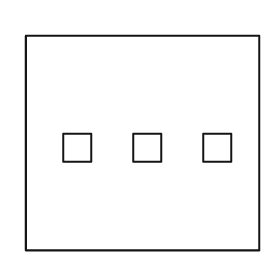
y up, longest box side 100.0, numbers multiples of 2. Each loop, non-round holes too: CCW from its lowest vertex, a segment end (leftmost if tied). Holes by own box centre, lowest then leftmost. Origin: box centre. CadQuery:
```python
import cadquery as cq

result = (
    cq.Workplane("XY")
    .moveTo(-50.0, -46.0)
    .lineTo(50.0, -46.0)
    .lineTo(50.0, 46.0)
    .lineTo(-50.0, 46.0)
    .close()
    .moveTo(-34.0, -8.0)
    .lineTo(-22.0, -8.0)
    .lineTo(-22.0, 4.0)
    .lineTo(-34.0, 4.0)
    .close()
    .moveTo(-4.0, -8.0)
    .lineTo(8.0, -8.0)
    .lineTo(8.0, 4.0)
    .lineTo(-4.0, 4.0)
    .close()
    .moveTo(26.0, -8.0)
    .lineTo(38.0, -8.0)
    .lineTo(38.0, 4.0)
    .lineTo(26.0, 4.0)
    .close()
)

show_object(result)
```